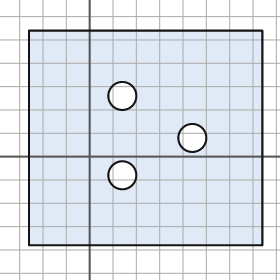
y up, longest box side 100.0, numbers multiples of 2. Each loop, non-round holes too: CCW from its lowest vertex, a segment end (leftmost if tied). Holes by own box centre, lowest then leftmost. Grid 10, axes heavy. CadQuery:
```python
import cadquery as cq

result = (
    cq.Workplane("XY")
    .moveTo(-26.0, -38.0)
    .lineTo(74.0, -38.0)
    .lineTo(74.0, 54.0)
    .lineTo(-26.0, 54.0)
    .close()
    .moveTo(14.0, -8.0)
    .circle(6.0)
    .moveTo(44.0, 8.0)
    .circle(6.0)
    .moveTo(14.0, 26.0)
    .circle(6.0)
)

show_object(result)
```